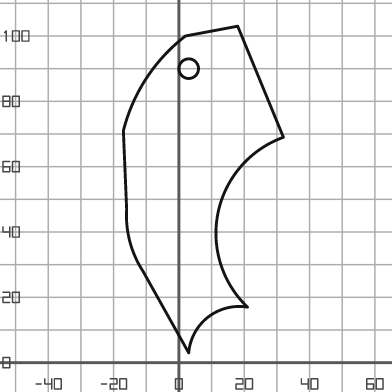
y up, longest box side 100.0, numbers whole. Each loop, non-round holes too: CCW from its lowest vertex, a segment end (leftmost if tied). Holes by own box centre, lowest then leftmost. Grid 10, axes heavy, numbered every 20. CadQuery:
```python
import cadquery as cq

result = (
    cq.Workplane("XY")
    .moveTo(3.0, 3.0)
    .threePointArc((9.0, 14.0), (21.0, 17.0))
    .threePointArc((12.0, 46.0), (32.0, 69.0))
    .lineTo(18.0, 103.0)
    .lineTo(2.0, 100.0)
    .threePointArc((-10.0, 87.0), (-17.0, 71.0))
    .lineTo(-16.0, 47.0)
    .threePointArc((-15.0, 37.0), (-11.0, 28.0))
    .close()
    .moveTo(3.0, 90.0)
    .circle(3.0)
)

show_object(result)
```